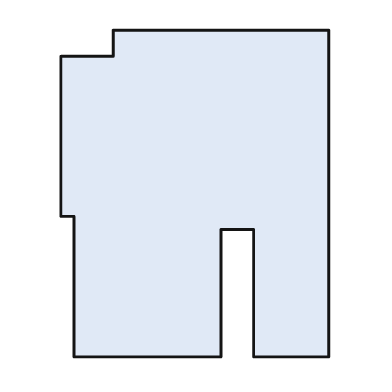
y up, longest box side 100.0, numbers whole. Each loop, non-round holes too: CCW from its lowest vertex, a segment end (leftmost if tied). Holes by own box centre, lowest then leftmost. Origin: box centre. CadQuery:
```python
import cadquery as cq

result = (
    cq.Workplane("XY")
    .moveTo(-37.0, -50.0)
    .lineTo(8.0, -50.0)
    .lineTo(8.0, -11.0)
    .lineTo(18.0, -11.0)
    .lineTo(18.0, -50.0)
    .lineTo(41.0, -50.0)
    .lineTo(41.0, 50.0)
    .lineTo(-25.0, 50.0)
    .lineTo(-25.0, 42.0)
    .lineTo(-41.0, 42.0)
    .lineTo(-41.0, -7.0)
    .lineTo(-37.0, -7.0)
    .close()
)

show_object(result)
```